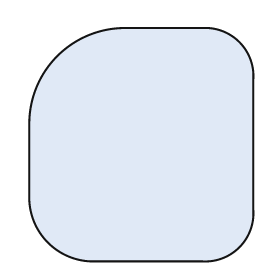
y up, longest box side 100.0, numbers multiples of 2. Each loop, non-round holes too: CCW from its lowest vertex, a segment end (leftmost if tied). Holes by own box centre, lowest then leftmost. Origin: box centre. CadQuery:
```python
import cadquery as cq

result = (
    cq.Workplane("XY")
    .moveTo(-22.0, -50.0)
    .lineTo(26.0, -50.0)
    .threePointArc((42.0, -44.0), (48.0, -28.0))
    .lineTo(48.0, 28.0)
    .threePointArc((42.0, 44.0), (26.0, 50.0))
    .lineTo(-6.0, 50.0)
    .threePointArc((-36.0, 38.0), (-48.0, 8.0))
    .lineTo(-48.0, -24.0)
    .threePointArc((-40.0, -42.0), (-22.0, -50.0))
    .close()
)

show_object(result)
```